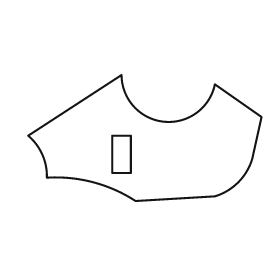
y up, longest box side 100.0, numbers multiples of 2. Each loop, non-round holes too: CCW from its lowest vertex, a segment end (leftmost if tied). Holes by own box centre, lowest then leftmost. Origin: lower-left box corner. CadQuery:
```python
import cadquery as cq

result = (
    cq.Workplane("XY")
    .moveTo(46.0, 0.0)
    .lineTo(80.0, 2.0)
    .threePointArc((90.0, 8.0), (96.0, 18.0))
    .lineTo(100.0, 36.0)
    .lineTo(80.0, 50.0)
    .threePointArc((58.0, 34.0), (40.0, 54.0))
    .lineTo(0.0, 28.0)
    .threePointArc((6.0, 20.0), (8.0, 10.0))
    .threePointArc((28.0, 8.0), (46.0, 0.0))
    .close()
    .moveTo(36.0, 12.0)
    .lineTo(44.0, 12.0)
    .lineTo(44.0, 28.0)
    .lineTo(36.0, 28.0)
    .close()
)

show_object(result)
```